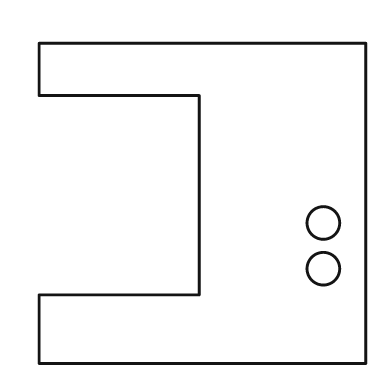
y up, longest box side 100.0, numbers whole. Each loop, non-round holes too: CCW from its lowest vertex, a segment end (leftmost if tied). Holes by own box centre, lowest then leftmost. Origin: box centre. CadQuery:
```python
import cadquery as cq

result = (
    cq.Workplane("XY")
    .moveTo(-50.0, -49.0)
    .lineTo(50.0, -49.0)
    .lineTo(50.0, 49.0)
    .lineTo(-50.0, 49.0)
    .lineTo(-50.0, 33.0)
    .lineTo(-1.0, 33.0)
    .lineTo(-1.0, -28.0)
    .lineTo(-50.0, -28.0)
    .close()
    .moveTo(37.0, -20.0)
    .circle(5.0)
    .moveTo(37.0, -6.0)
    .circle(5.0)
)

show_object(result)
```